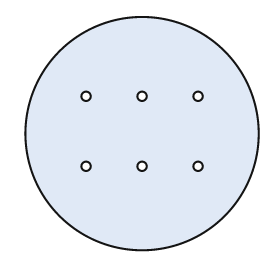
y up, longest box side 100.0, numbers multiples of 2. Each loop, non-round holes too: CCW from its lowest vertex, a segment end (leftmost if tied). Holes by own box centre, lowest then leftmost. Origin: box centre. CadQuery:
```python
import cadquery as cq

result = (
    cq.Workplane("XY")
    .moveTo(0.0, 0.0)
    .circle(50.0)
    .moveTo(-24.0, -14.0)
    .circle(2.0)
    .moveTo(0.0, -14.0)
    .circle(2.0)
    .moveTo(24.0, -14.0)
    .circle(2.0)
    .moveTo(-24.0, 16.0)
    .circle(2.0)
    .moveTo(0.0, 16.0)
    .circle(2.0)
    .moveTo(24.0, 16.0)
    .circle(2.0)
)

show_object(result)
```